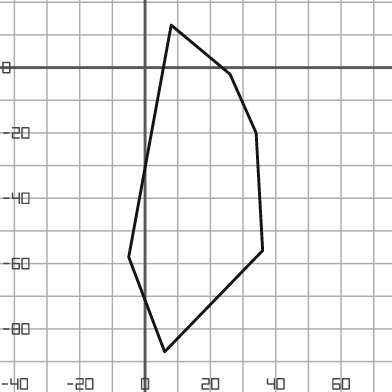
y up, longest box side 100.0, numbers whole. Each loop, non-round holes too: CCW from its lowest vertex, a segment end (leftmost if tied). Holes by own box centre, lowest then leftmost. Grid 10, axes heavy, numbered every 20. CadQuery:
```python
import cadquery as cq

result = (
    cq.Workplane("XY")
    .moveTo(6.0, -87.0)
    .lineTo(36.0, -56.0)
    .lineTo(34.0, -20.0)
    .lineTo(26.0, -2.0)
    .lineTo(8.0, 13.0)
    .lineTo(-5.0, -58.0)
    .close()
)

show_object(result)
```